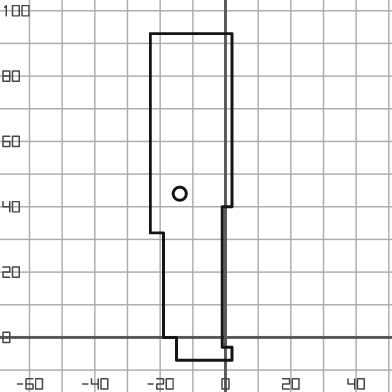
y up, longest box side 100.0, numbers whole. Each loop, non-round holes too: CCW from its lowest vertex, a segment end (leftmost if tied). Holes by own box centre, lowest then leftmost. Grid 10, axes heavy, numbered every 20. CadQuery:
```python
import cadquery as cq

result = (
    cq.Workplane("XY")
    .moveTo(-15.0, -7.0)
    .lineTo(2.0, -7.0)
    .lineTo(2.0, -3.0)
    .lineTo(-1.0, -3.0)
    .lineTo(-1.0, 40.0)
    .lineTo(2.0, 40.0)
    .lineTo(2.0, 93.0)
    .lineTo(-23.0, 93.0)
    .lineTo(-23.0, 32.0)
    .lineTo(-19.0, 32.0)
    .lineTo(-19.0, 0.0)
    .lineTo(-15.0, 0.0)
    .close()
    .moveTo(-14.0, 44.0)
    .circle(2.0)
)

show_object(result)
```